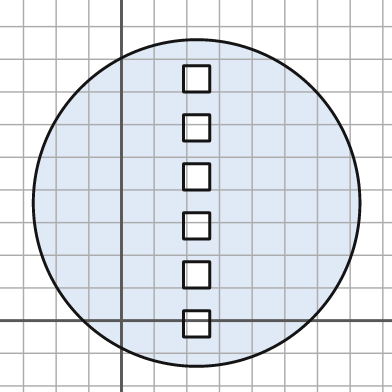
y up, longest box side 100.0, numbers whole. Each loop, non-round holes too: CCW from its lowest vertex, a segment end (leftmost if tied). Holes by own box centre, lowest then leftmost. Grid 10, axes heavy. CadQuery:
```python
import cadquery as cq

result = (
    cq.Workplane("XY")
    .moveTo(23.0, 36.0)
    .circle(50.0)
    .moveTo(19.0, -5.0)
    .lineTo(27.0, -5.0)
    .lineTo(27.0, 3.0)
    .lineTo(19.0, 3.0)
    .close()
    .moveTo(19.0, 10.0)
    .lineTo(27.0, 10.0)
    .lineTo(27.0, 18.0)
    .lineTo(19.0, 18.0)
    .close()
    .moveTo(19.0, 25.0)
    .lineTo(27.0, 25.0)
    .lineTo(27.0, 33.0)
    .lineTo(19.0, 33.0)
    .close()
    .moveTo(19.0, 40.0)
    .lineTo(27.0, 40.0)
    .lineTo(27.0, 48.0)
    .lineTo(19.0, 48.0)
    .close()
    .moveTo(19.0, 55.0)
    .lineTo(27.0, 55.0)
    .lineTo(27.0, 63.0)
    .lineTo(19.0, 63.0)
    .close()
    .moveTo(19.0, 70.0)
    .lineTo(27.0, 70.0)
    .lineTo(27.0, 78.0)
    .lineTo(19.0, 78.0)
    .close()
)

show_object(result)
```